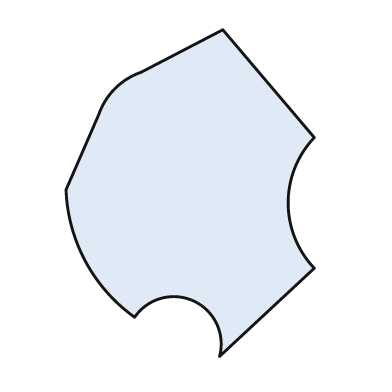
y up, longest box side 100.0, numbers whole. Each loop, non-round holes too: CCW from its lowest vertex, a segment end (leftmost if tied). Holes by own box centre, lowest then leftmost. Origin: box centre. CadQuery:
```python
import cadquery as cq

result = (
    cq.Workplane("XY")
    .moveTo(9.0, -50.0)
    .lineTo(38.0, -23.0)
    .threePointArc((30.0, -3.0), (38.0, 17.0))
    .lineTo(10.0, 50.0)
    .lineTo(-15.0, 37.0)
    .threePointArc((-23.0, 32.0), (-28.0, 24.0))
    .lineTo(-38.0, 1.0)
    .threePointArc((-32.0, -21.0), (-17.0, -38.0))
    .threePointArc((1.0, -33.0), (9.0, -50.0))
    .close()
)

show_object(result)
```